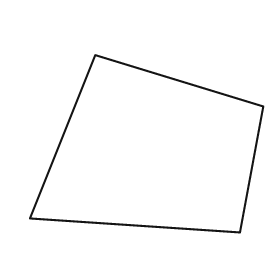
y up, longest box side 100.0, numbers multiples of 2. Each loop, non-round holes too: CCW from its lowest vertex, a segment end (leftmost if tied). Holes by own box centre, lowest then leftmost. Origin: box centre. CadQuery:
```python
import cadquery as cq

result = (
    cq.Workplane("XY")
    .moveTo(40.0, -38.0)
    .lineTo(50.0, 16.0)
    .lineTo(-22.0, 38.0)
    .lineTo(-50.0, -32.0)
    .close()
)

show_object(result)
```